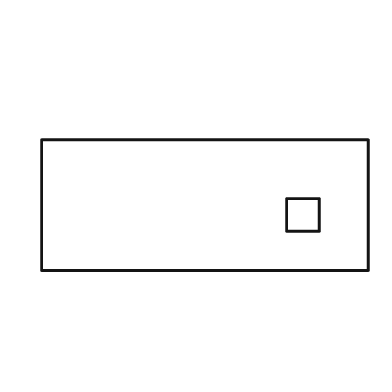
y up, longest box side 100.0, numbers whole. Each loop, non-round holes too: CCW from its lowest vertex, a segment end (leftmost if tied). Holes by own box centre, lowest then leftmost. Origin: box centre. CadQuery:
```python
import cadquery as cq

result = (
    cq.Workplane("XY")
    .moveTo(-50.0, -20.0)
    .lineTo(50.0, -20.0)
    .lineTo(50.0, 20.0)
    .lineTo(-50.0, 20.0)
    .close()
    .moveTo(25.0, -8.0)
    .lineTo(35.0, -8.0)
    .lineTo(35.0, 2.0)
    .lineTo(25.0, 2.0)
    .close()
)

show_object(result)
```